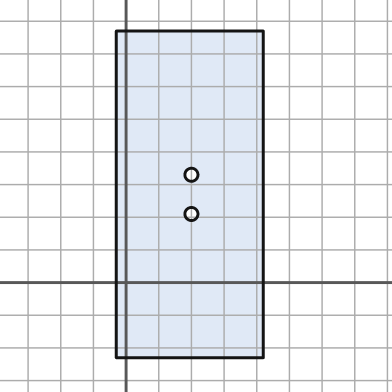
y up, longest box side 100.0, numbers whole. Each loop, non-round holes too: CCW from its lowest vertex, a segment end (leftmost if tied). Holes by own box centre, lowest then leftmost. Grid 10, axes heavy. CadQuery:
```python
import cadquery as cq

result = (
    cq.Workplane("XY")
    .moveTo(-3.0, -23.0)
    .lineTo(42.0, -23.0)
    .lineTo(42.0, 77.0)
    .lineTo(-3.0, 77.0)
    .close()
    .moveTo(20.0, 21.0)
    .circle(2.0)
    .moveTo(20.0, 33.0)
    .circle(2.0)
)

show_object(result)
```